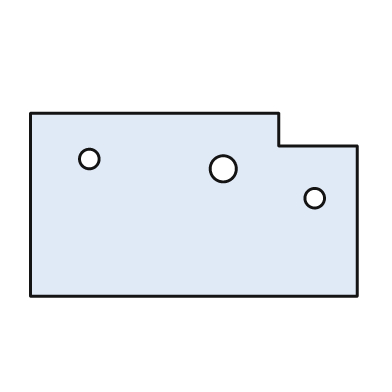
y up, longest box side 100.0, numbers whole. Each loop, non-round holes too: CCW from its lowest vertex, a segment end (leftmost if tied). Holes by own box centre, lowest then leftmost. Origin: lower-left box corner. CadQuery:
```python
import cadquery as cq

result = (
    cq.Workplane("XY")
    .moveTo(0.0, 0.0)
    .lineTo(100.0, 0.0)
    .lineTo(100.0, 46.0)
    .lineTo(76.0, 46.0)
    .lineTo(76.0, 56.0)
    .lineTo(0.0, 56.0)
    .close()
    .moveTo(87.0, 30.0)
    .circle(3.0)
    .moveTo(59.0, 39.0)
    .circle(4.0)
    .moveTo(18.0, 42.0)
    .circle(3.0)
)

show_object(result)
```